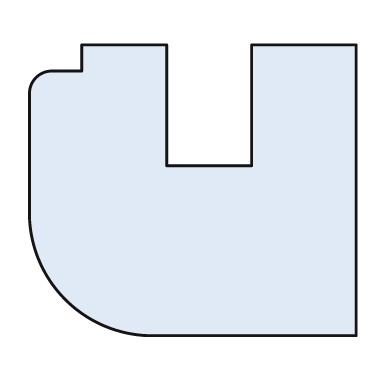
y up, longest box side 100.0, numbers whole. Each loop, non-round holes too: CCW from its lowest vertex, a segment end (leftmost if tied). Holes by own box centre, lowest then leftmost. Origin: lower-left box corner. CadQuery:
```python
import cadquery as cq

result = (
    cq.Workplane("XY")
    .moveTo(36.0, 0.0)
    .lineTo(100.0, 0.0)
    .lineTo(100.0, 89.0)
    .lineTo(68.0, 89.0)
    .lineTo(68.0, 52.0)
    .lineTo(42.0, 52.0)
    .lineTo(42.0, 89.0)
    .lineTo(16.0, 89.0)
    .lineTo(16.0, 81.0)
    .lineTo(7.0, 81.0)
    .threePointArc((2.0, 79.0), (0.0, 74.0))
    .lineTo(0.0, 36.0)
    .threePointArc((11.0, 11.0), (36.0, 0.0))
    .close()
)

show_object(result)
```